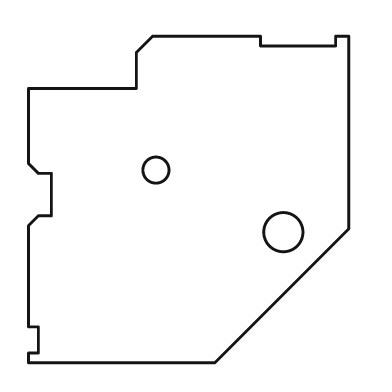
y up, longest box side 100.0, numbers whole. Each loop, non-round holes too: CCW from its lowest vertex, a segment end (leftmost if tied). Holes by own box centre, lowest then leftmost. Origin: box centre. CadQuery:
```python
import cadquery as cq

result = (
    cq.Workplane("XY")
    .moveTo(-49.0, -50.0)
    .lineTo(8.0, -50.0)
    .lineTo(49.0, -9.0)
    .lineTo(49.0, 50.0)
    .lineTo(45.0, 50.0)
    .lineTo(45.0, 47.0)
    .lineTo(22.0, 47.0)
    .lineTo(22.0, 50.0)
    .lineTo(-11.0, 50.0)
    .lineTo(-16.0, 45.0)
    .lineTo(-16.0, 34.0)
    .lineTo(-49.0, 34.0)
    .lineTo(-49.0, 11.0)
    .lineTo(-46.0, 8.0)
    .lineTo(-42.0, 8.0)
    .lineTo(-42.0, -5.0)
    .lineTo(-46.0, -5.0)
    .lineTo(-49.0, -8.0)
    .lineTo(-49.0, -39.0)
    .lineTo(-46.0, -39.0)
    .lineTo(-46.0, -47.0)
    .lineTo(-49.0, -47.0)
    .close()
    .moveTo(29.0, -10.0)
    .circle(6.0)
    .moveTo(-10.0, 9.0)
    .circle(4.0)
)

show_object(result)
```